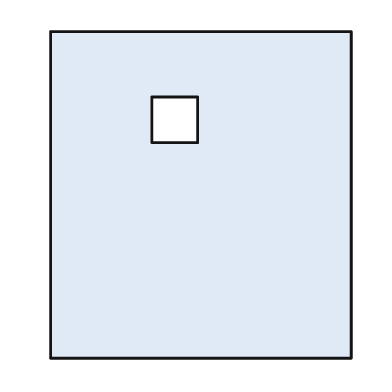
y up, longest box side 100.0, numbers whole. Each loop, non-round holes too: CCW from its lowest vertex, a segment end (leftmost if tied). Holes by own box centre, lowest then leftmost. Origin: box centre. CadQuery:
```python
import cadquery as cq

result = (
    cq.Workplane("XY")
    .moveTo(-46.0, -50.0)
    .lineTo(46.0, -50.0)
    .lineTo(46.0, 50.0)
    .lineTo(-46.0, 50.0)
    .close()
    .moveTo(-15.0, 16.0)
    .lineTo(-1.0, 16.0)
    .lineTo(-1.0, 30.0)
    .lineTo(-15.0, 30.0)
    .close()
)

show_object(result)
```